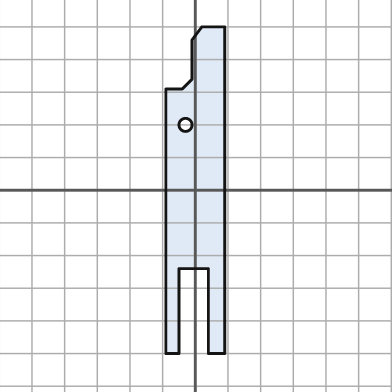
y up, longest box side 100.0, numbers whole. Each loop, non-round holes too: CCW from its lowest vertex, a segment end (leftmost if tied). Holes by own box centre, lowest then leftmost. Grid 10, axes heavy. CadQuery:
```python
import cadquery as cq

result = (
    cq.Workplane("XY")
    .moveTo(-9.0, -50.0)
    .lineTo(-5.0, -50.0)
    .lineTo(-5.0, -24.0)
    .lineTo(4.0, -24.0)
    .lineTo(4.0, -50.0)
    .lineTo(9.0, -50.0)
    .lineTo(9.0, 50.0)
    .lineTo(2.0, 50.0)
    .lineTo(-1.0, 46.0)
    .lineTo(-1.0, 34.0)
    .lineTo(-4.0, 31.0)
    .lineTo(-9.0, 31.0)
    .close()
    .moveTo(-3.0, 20.0)
    .circle(2.0)
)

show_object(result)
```